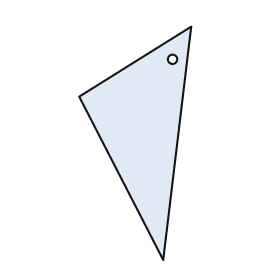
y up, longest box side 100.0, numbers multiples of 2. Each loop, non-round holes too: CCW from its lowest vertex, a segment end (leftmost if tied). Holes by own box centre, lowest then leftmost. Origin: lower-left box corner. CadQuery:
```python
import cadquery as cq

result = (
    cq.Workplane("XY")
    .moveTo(36.0, 0.0)
    .lineTo(48.0, 100.0)
    .lineTo(0.0, 70.0)
    .close()
    .moveTo(40.0, 86.0)
    .circle(2.0)
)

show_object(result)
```